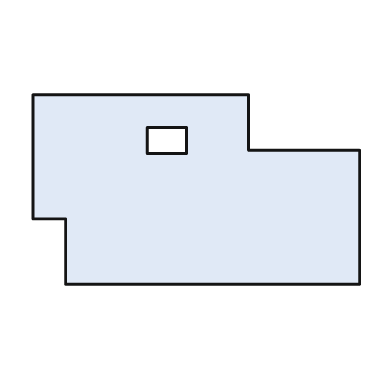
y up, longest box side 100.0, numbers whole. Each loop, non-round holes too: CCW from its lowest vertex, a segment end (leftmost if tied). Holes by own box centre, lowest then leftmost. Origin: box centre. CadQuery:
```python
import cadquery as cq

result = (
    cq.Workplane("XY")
    .moveTo(-40.0, -29.0)
    .lineTo(50.0, -29.0)
    .lineTo(50.0, 12.0)
    .lineTo(16.0, 12.0)
    .lineTo(16.0, 29.0)
    .lineTo(-50.0, 29.0)
    .lineTo(-50.0, -9.0)
    .lineTo(-40.0, -9.0)
    .close()
    .moveTo(-15.0, 11.0)
    .lineTo(-3.0, 11.0)
    .lineTo(-3.0, 19.0)
    .lineTo(-15.0, 19.0)
    .close()
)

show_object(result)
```